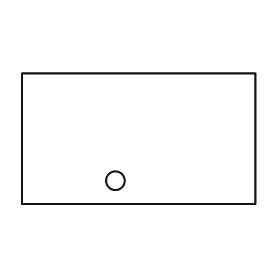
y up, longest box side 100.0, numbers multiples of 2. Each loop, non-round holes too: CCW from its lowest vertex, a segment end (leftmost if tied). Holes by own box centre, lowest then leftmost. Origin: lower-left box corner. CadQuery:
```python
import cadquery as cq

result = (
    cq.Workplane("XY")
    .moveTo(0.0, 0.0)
    .lineTo(100.0, 0.0)
    .lineTo(100.0, 56.0)
    .lineTo(0.0, 56.0)
    .close()
    .moveTo(40.0, 10.0)
    .circle(4.0)
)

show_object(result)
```